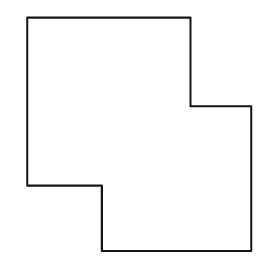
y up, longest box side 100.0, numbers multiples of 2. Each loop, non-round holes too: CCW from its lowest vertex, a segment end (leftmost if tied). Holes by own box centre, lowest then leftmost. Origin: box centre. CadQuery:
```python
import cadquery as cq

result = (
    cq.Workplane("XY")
    .moveTo(-16.0, -50.0)
    .lineTo(48.0, -50.0)
    .lineTo(48.0, 12.0)
    .lineTo(22.0, 12.0)
    .lineTo(22.0, 50.0)
    .lineTo(-48.0, 50.0)
    .lineTo(-48.0, -22.0)
    .lineTo(-16.0, -22.0)
    .close()
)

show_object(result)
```